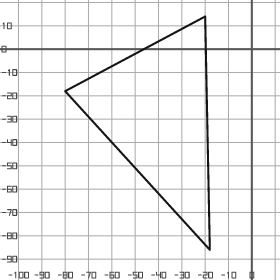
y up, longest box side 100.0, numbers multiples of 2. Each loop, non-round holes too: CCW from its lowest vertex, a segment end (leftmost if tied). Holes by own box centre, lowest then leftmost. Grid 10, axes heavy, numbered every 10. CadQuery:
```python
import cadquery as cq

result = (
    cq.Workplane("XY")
    .moveTo(-18.0, -86.0)
    .lineTo(-20.0, 14.0)
    .lineTo(-80.0, -18.0)
    .close()
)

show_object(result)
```